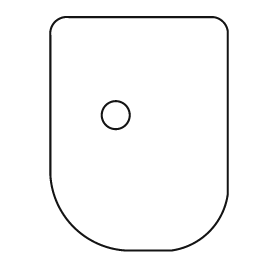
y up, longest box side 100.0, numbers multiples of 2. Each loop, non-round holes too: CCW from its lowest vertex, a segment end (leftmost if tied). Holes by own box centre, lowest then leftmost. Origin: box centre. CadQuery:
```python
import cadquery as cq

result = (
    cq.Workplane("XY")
    .moveTo(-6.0, -50.0)
    .lineTo(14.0, -50.0)
    .threePointArc((30.0, -42.0), (38.0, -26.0))
    .lineTo(38.0, 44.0)
    .threePointArc((36.0, 48.0), (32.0, 50.0))
    .lineTo(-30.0, 50.0)
    .threePointArc((-36.0, 48.0), (-38.0, 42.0))
    .lineTo(-38.0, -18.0)
    .threePointArc((-28.0, -40.0), (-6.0, -50.0))
    .close()
    .moveTo(-10.0, 8.0)
    .circle(6.0)
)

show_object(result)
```